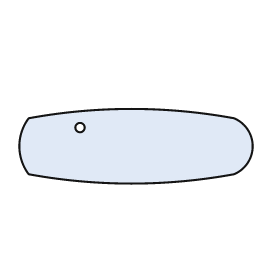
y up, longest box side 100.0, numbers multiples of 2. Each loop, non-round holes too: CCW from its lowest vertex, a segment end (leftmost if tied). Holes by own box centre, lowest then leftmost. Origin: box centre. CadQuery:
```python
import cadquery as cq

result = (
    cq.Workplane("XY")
    .moveTo(-46.0, -12.0)
    .threePointArc((-2.0, -16.0), (42.0, -12.0))
    .threePointArc((50.0, 0.0), (42.0, 12.0))
    .threePointArc((-2.0, 16.0), (-46.0, 12.0))
    .threePointArc((-50.0, 0.0), (-46.0, -12.0))
    .close()
    .moveTo(-24.0, 8.0)
    .circle(2.0)
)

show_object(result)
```